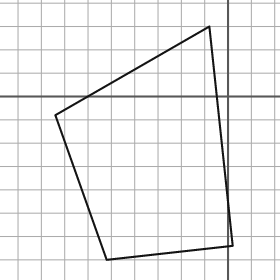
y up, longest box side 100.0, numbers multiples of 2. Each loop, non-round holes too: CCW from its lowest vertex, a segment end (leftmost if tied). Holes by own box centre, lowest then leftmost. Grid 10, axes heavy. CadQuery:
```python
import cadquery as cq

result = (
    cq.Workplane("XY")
    .moveTo(-52.0, -70.0)
    .lineTo(2.0, -64.0)
    .lineTo(-8.0, 30.0)
    .lineTo(-74.0, -8.0)
    .close()
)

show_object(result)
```